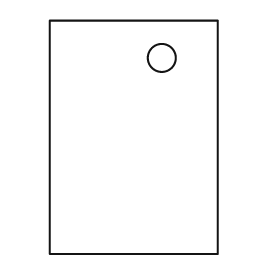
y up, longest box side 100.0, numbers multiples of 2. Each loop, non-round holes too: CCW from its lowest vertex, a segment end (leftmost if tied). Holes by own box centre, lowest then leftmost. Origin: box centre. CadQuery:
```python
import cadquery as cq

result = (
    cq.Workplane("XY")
    .moveTo(-36.0, -50.0)
    .lineTo(36.0, -50.0)
    .lineTo(36.0, 50.0)
    .lineTo(-36.0, 50.0)
    .close()
    .moveTo(12.0, 34.0)
    .circle(6.0)
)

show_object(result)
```